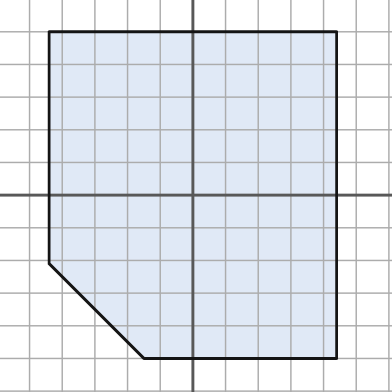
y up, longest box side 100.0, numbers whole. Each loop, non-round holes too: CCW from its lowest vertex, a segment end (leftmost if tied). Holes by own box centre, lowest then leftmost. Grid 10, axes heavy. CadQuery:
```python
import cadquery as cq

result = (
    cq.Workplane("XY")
    .moveTo(-15.0, -50.0)
    .lineTo(44.0, -50.0)
    .lineTo(44.0, 50.0)
    .lineTo(-44.0, 50.0)
    .lineTo(-44.0, -21.0)
    .close()
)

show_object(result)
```